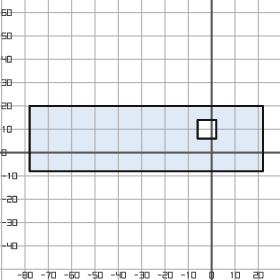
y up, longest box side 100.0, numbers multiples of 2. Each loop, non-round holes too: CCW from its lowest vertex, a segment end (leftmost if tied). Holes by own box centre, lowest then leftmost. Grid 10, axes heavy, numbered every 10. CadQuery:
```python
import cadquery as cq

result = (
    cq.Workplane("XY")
    .moveTo(-78.0, -8.0)
    .lineTo(22.0, -8.0)
    .lineTo(22.0, 20.0)
    .lineTo(-78.0, 20.0)
    .close()
    .moveTo(-6.0, 6.0)
    .lineTo(2.0, 6.0)
    .lineTo(2.0, 14.0)
    .lineTo(-6.0, 14.0)
    .close()
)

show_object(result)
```